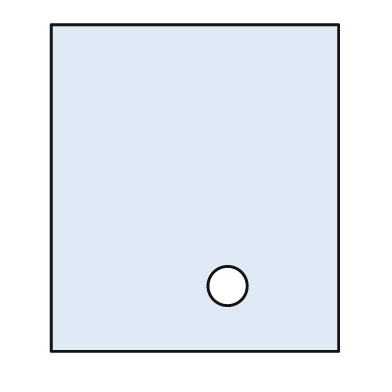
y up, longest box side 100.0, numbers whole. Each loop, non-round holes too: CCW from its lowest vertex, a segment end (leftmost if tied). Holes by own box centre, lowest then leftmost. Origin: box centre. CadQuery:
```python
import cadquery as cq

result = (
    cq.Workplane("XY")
    .moveTo(-44.0, -50.0)
    .lineTo(44.0, -50.0)
    .lineTo(44.0, 50.0)
    .lineTo(-44.0, 50.0)
    .close()
    .moveTo(10.0, -30.0)
    .circle(6.0)
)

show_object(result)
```